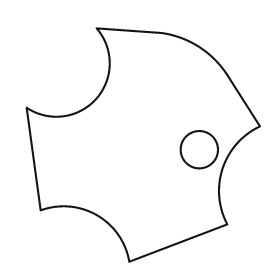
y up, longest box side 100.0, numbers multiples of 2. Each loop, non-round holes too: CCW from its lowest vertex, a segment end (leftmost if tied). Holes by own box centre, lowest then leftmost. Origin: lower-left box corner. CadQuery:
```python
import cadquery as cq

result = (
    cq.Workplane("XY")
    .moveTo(44.0, 0.0)
    .lineTo(86.0, 16.0)
    .threePointArc((84.0, 40.0), (100.0, 58.0))
    .lineTo(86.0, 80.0)
    .threePointArc((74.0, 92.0), (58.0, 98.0))
    .lineTo(30.0, 100.0)
    .threePointArc((30.0, 70.0), (0.0, 66.0))
    .lineTo(6.0, 22.0)
    .threePointArc((30.0, 20.0), (44.0, 0.0))
    .close()
    .moveTo(74.0, 48.0)
    .circle(8.0)
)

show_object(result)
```